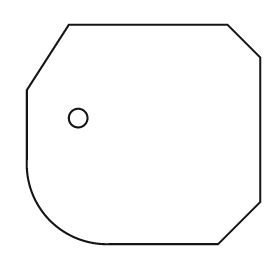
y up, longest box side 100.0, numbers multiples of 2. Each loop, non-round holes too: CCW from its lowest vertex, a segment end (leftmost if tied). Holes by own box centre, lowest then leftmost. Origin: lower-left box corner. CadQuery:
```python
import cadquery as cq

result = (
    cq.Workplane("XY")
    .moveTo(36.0, 0.0)
    .lineTo(82.0, 0.0)
    .lineTo(100.0, 18.0)
    .lineTo(100.0, 80.0)
    .lineTo(86.0, 94.0)
    .lineTo(18.0, 94.0)
    .lineTo(0.0, 66.0)
    .lineTo(0.0, 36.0)
    .threePointArc((10.0, 10.0), (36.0, 0.0))
    .close()
    .moveTo(22.0, 54.0)
    .circle(4.0)
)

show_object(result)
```